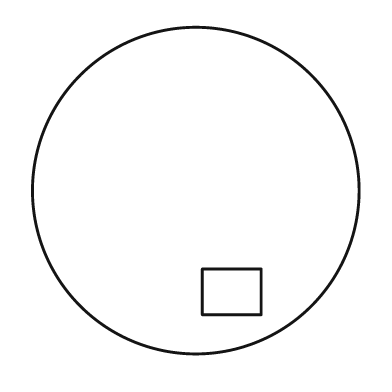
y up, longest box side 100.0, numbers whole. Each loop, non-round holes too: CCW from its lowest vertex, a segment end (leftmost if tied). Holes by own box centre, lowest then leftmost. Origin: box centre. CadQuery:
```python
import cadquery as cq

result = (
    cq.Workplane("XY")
    .moveTo(0.0, 0.0)
    .circle(50.0)
    .moveTo(2.0, -38.0)
    .lineTo(20.0, -38.0)
    .lineTo(20.0, -24.0)
    .lineTo(2.0, -24.0)
    .close()
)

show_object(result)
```